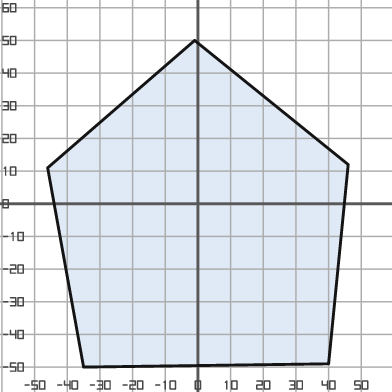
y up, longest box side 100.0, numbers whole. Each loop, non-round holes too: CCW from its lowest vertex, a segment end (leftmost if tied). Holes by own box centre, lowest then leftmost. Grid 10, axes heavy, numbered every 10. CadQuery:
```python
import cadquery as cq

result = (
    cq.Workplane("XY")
    .moveTo(-35.0, -50.0)
    .lineTo(40.0, -49.0)
    .lineTo(46.0, 12.0)
    .lineTo(-1.0, 50.0)
    .lineTo(-46.0, 11.0)
    .close()
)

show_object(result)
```